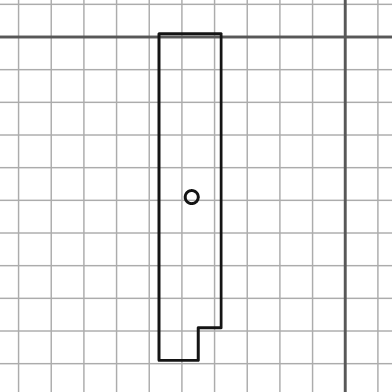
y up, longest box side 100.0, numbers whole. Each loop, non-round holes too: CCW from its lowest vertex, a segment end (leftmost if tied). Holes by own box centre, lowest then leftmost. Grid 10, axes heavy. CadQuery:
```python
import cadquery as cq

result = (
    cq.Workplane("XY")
    .moveTo(-57.0, -99.0)
    .lineTo(-45.0, -99.0)
    .lineTo(-45.0, -89.0)
    .lineTo(-38.0, -89.0)
    .lineTo(-38.0, 1.0)
    .lineTo(-57.0, 1.0)
    .close()
    .moveTo(-47.0, -49.0)
    .circle(2.0)
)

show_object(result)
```